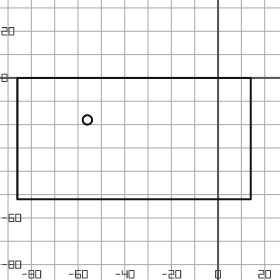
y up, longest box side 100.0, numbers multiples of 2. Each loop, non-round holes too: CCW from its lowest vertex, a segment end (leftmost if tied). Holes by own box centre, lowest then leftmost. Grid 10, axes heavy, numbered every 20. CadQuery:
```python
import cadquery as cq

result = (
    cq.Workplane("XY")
    .moveTo(-86.0, -52.0)
    .lineTo(14.0, -52.0)
    .lineTo(14.0, 0.0)
    .lineTo(-86.0, 0.0)
    .close()
    .moveTo(-56.0, -18.0)
    .circle(2.0)
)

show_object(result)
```